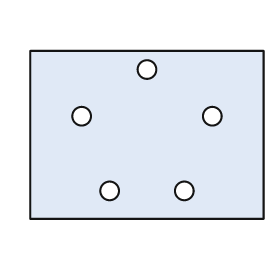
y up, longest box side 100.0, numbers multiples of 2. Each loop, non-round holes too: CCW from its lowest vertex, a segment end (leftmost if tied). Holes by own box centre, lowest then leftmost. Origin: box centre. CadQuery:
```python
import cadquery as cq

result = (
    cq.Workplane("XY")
    .moveTo(-50.0, -36.0)
    .lineTo(50.0, -36.0)
    .lineTo(50.0, 36.0)
    .lineTo(-50.0, 36.0)
    .close()
    .moveTo(-16.0, -24.0)
    .circle(4.0)
    .moveTo(16.0, -24.0)
    .circle(4.0)
    .moveTo(-28.0, 8.0)
    .circle(4.0)
    .moveTo(28.0, 8.0)
    .circle(4.0)
    .moveTo(0.0, 28.0)
    .circle(4.0)
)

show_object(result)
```